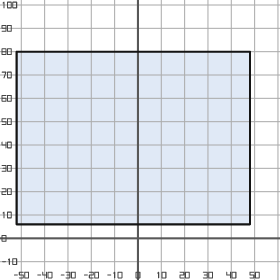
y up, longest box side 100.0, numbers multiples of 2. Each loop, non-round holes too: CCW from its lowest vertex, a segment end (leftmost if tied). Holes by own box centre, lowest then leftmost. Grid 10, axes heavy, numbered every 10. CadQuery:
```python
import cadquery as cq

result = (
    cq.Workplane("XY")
    .moveTo(-52.0, 6.0)
    .lineTo(48.0, 6.0)
    .lineTo(48.0, 80.0)
    .lineTo(-52.0, 80.0)
    .close()
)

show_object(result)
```